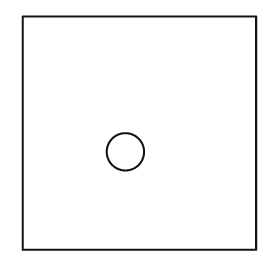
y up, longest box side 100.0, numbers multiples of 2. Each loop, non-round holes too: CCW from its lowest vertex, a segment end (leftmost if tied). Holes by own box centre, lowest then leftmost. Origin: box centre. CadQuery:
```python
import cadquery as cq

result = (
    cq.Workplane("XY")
    .moveTo(-50.0, -50.0)
    .lineTo(50.0, -50.0)
    .lineTo(50.0, 50.0)
    .lineTo(-50.0, 50.0)
    .close()
    .moveTo(-6.0, -8.0)
    .circle(8.0)
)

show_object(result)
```